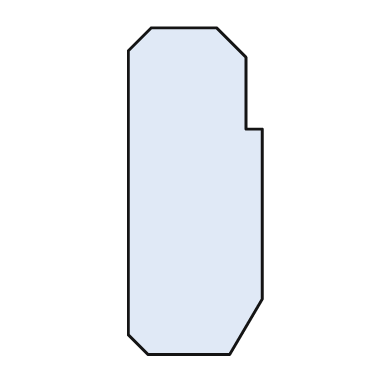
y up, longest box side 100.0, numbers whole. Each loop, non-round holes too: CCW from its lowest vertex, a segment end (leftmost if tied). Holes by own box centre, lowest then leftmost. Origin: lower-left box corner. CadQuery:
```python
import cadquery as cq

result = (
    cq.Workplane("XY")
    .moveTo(6.0, 0.0)
    .lineTo(31.0, 0.0)
    .lineTo(41.0, 17.0)
    .lineTo(41.0, 69.0)
    .lineTo(36.0, 69.0)
    .lineTo(36.0, 91.0)
    .lineTo(27.0, 100.0)
    .lineTo(7.0, 100.0)
    .lineTo(0.0, 93.0)
    .lineTo(0.0, 6.0)
    .close()
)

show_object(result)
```